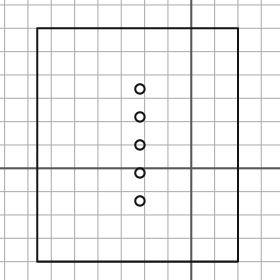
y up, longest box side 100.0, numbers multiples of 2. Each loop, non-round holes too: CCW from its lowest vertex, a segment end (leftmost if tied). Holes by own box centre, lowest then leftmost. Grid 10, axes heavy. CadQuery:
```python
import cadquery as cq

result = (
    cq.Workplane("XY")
    .moveTo(-66.0, -40.0)
    .lineTo(20.0, -40.0)
    .lineTo(20.0, 60.0)
    .lineTo(-66.0, 60.0)
    .close()
    .moveTo(-22.0, -14.0)
    .circle(2.0)
    .moveTo(-22.0, -2.0)
    .circle(2.0)
    .moveTo(-22.0, 10.0)
    .circle(2.0)
    .moveTo(-22.0, 22.0)
    .circle(2.0)
    .moveTo(-22.0, 34.0)
    .circle(2.0)
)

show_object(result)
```